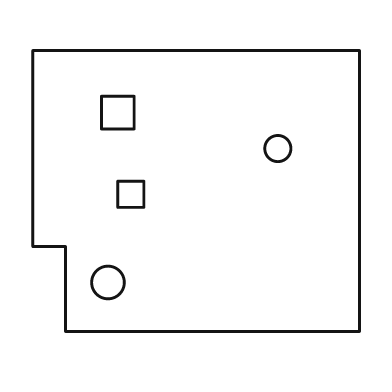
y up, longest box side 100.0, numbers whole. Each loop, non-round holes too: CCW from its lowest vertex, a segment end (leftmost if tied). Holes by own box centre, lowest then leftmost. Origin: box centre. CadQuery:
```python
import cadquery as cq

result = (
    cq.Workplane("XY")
    .moveTo(-40.0, -43.0)
    .lineTo(50.0, -43.0)
    .lineTo(50.0, 43.0)
    .lineTo(-50.0, 43.0)
    .lineTo(-50.0, -17.0)
    .lineTo(-40.0, -17.0)
    .close()
    .moveTo(-27.0, -28.0)
    .circle(5.0)
    .moveTo(-24.0, -5.0)
    .lineTo(-16.0, -5.0)
    .lineTo(-16.0, 3.0)
    .lineTo(-24.0, 3.0)
    .close()
    .moveTo(25.0, 13.0)
    .circle(4.0)
    .moveTo(-29.0, 19.0)
    .lineTo(-19.0, 19.0)
    .lineTo(-19.0, 29.0)
    .lineTo(-29.0, 29.0)
    .close()
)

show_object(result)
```